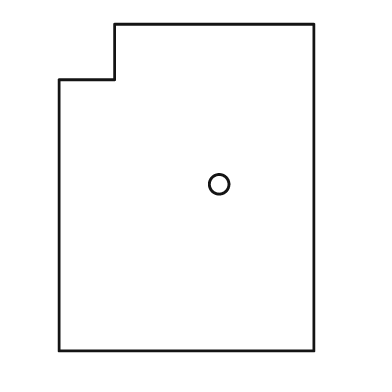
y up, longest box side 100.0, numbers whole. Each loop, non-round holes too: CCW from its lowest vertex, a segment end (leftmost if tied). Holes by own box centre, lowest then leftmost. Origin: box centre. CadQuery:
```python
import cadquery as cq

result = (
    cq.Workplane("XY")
    .moveTo(-39.0, -50.0)
    .lineTo(39.0, -50.0)
    .lineTo(39.0, 50.0)
    .lineTo(-22.0, 50.0)
    .lineTo(-22.0, 33.0)
    .lineTo(-39.0, 33.0)
    .close()
    .moveTo(10.0, 1.0)
    .circle(3.0)
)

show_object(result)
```